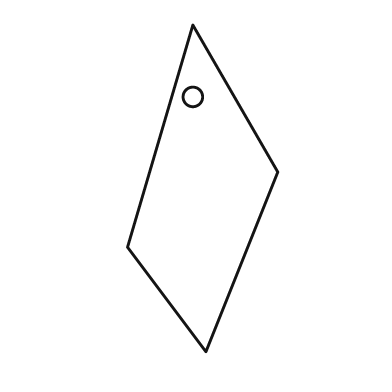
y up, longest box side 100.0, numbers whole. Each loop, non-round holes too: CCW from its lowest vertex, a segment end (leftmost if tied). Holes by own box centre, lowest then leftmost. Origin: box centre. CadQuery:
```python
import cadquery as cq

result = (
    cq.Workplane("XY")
    .moveTo(1.0, -50.0)
    .lineTo(23.0, 5.0)
    .lineTo(-3.0, 50.0)
    .lineTo(-23.0, -18.0)
    .close()
    .moveTo(-3.0, 28.0)
    .circle(3.0)
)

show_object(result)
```